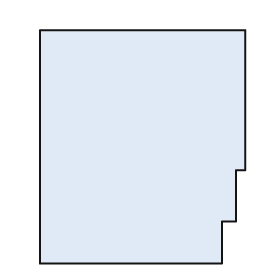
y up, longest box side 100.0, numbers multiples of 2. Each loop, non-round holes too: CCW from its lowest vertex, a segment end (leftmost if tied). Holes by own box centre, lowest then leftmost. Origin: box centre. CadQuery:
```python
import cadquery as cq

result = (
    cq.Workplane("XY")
    .moveTo(-44.0, -50.0)
    .lineTo(34.0, -50.0)
    .lineTo(34.0, -32.0)
    .lineTo(40.0, -32.0)
    .lineTo(40.0, -10.0)
    .lineTo(44.0, -10.0)
    .lineTo(44.0, 50.0)
    .lineTo(-44.0, 50.0)
    .close()
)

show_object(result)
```